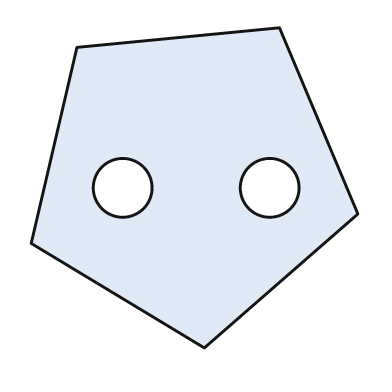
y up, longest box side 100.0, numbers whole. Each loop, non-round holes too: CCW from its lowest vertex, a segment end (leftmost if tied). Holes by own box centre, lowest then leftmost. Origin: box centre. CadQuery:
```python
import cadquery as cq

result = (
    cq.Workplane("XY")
    .moveTo(3.0, -49.0)
    .lineTo(50.0, -8.0)
    .lineTo(26.0, 49.0)
    .lineTo(-36.0, 43.0)
    .lineTo(-50.0, -17.0)
    .close()
    .moveTo(-22.0, 0.0)
    .circle(9.0)
    .moveTo(23.0, 0.0)
    .circle(9.0)
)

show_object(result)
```